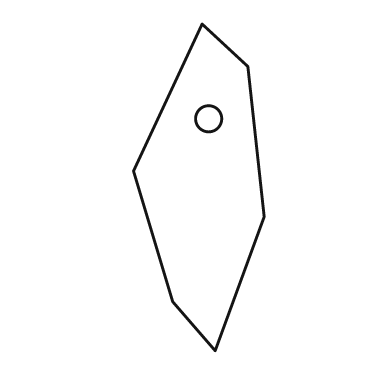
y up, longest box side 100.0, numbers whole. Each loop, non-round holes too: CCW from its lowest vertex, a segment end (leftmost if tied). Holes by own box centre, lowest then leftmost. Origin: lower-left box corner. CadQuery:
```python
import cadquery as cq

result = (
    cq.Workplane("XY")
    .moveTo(25.0, 0.0)
    .lineTo(40.0, 41.0)
    .lineTo(35.0, 87.0)
    .lineTo(21.0, 100.0)
    .lineTo(0.0, 55.0)
    .lineTo(12.0, 15.0)
    .close()
    .moveTo(23.0, 71.0)
    .circle(4.0)
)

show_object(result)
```